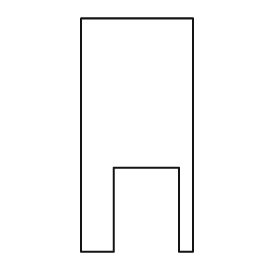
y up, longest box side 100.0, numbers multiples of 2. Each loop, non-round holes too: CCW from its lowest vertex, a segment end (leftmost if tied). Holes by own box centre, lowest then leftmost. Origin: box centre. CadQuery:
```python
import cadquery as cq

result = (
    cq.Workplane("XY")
    .moveTo(-24.0, -50.0)
    .lineTo(-10.0, -50.0)
    .lineTo(-10.0, -14.0)
    .lineTo(18.0, -14.0)
    .lineTo(18.0, -50.0)
    .lineTo(24.0, -50.0)
    .lineTo(24.0, 50.0)
    .lineTo(-24.0, 50.0)
    .close()
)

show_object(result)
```